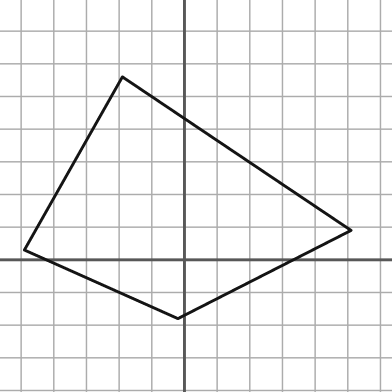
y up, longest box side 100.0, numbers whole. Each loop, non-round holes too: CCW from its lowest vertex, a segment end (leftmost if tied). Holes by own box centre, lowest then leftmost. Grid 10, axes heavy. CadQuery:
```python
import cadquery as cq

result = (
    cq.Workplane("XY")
    .moveTo(-2.0, -18.0)
    .lineTo(51.0, 9.0)
    .lineTo(-19.0, 56.0)
    .lineTo(-49.0, 3.0)
    .close()
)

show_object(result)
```